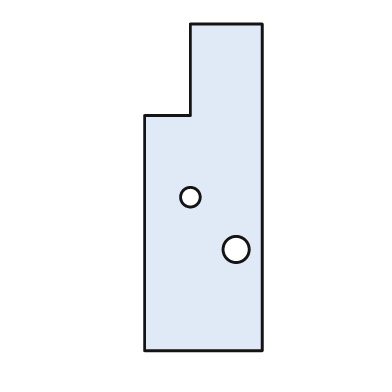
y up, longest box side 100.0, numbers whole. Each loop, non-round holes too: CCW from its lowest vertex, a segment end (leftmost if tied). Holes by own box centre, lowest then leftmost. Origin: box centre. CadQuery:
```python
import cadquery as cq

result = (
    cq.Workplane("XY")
    .moveTo(-18.0, -50.0)
    .lineTo(18.0, -50.0)
    .lineTo(18.0, 50.0)
    .lineTo(-4.0, 50.0)
    .lineTo(-4.0, 22.0)
    .lineTo(-18.0, 22.0)
    .close()
    .moveTo(10.0, -19.0)
    .circle(4.0)
    .moveTo(-4.0, -3.0)
    .circle(3.0)
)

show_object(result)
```